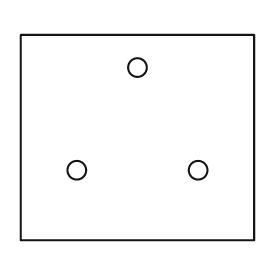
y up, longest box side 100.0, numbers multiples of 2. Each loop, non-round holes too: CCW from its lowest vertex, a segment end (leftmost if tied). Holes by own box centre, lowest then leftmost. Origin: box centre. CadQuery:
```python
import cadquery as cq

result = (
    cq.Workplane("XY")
    .moveTo(-50.0, -44.0)
    .lineTo(50.0, -44.0)
    .lineTo(50.0, 44.0)
    .lineTo(-50.0, 44.0)
    .close()
    .moveTo(-26.0, -14.0)
    .circle(4.0)
    .moveTo(26.0, -14.0)
    .circle(4.0)
    .moveTo(0.0, 30.0)
    .circle(4.0)
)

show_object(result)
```